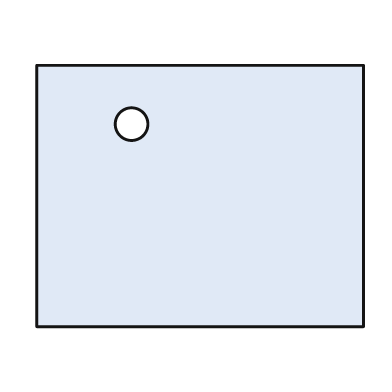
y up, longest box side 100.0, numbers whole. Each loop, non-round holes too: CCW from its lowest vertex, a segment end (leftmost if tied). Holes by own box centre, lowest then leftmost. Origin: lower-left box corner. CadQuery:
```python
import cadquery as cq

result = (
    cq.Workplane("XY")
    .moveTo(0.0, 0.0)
    .lineTo(100.0, 0.0)
    .lineTo(100.0, 80.0)
    .lineTo(0.0, 80.0)
    .close()
    .moveTo(29.0, 62.0)
    .circle(5.0)
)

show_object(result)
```